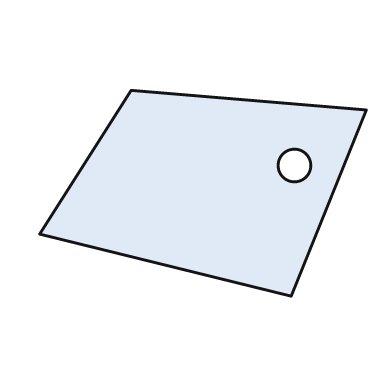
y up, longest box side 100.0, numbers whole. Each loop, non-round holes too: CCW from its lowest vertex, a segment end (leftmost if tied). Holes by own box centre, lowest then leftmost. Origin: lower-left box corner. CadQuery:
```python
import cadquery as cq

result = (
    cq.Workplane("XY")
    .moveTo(77.0, 0.0)
    .lineTo(100.0, 57.0)
    .lineTo(28.0, 63.0)
    .lineTo(0.0, 19.0)
    .close()
    .moveTo(78.0, 40.0)
    .circle(5.0)
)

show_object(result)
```